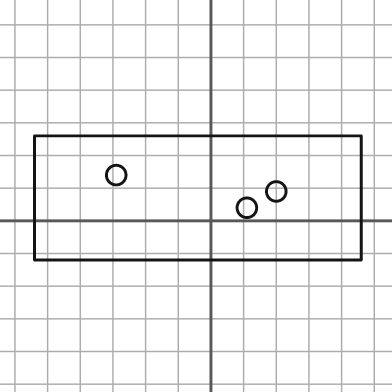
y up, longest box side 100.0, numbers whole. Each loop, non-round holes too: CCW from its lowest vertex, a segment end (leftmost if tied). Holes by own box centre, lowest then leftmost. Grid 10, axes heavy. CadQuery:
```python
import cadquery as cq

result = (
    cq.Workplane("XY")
    .moveTo(-54.0, -12.0)
    .lineTo(46.0, -12.0)
    .lineTo(46.0, 26.0)
    .lineTo(-54.0, 26.0)
    .close()
    .moveTo(11.0, 4.0)
    .circle(3.0)
    .moveTo(20.0, 9.0)
    .circle(3.0)
    .moveTo(-29.0, 14.0)
    .circle(3.0)
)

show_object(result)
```